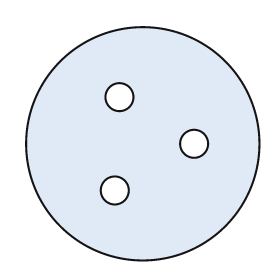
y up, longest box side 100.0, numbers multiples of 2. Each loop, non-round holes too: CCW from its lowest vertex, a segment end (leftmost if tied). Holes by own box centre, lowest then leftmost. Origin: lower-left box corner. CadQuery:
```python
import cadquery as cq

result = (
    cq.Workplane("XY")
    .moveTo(50.0, 50.0)
    .circle(50.0)
    .moveTo(38.0, 30.0)
    .circle(6.0)
    .moveTo(72.0, 50.0)
    .circle(6.0)
    .moveTo(40.0, 70.0)
    .circle(6.0)
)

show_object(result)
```